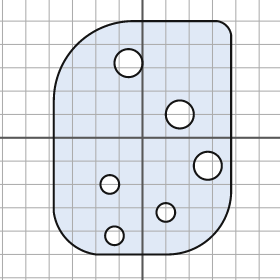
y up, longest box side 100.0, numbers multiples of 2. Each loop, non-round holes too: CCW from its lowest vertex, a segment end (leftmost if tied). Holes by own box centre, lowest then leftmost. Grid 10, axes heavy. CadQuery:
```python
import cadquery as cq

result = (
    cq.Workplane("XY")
    .moveTo(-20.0, -50.0)
    .lineTo(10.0, -50.0)
    .threePointArc((30.0, -42.0), (38.0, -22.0))
    .lineTo(38.0, 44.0)
    .threePointArc((36.0, 48.0), (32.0, 50.0))
    .lineTo(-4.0, 50.0)
    .threePointArc((-28.0, 40.0), (-38.0, 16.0))
    .lineTo(-38.0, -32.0)
    .threePointArc((-32.0, -44.0), (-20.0, -50.0))
    .close()
    .moveTo(-12.0, -42.0)
    .circle(4.0)
    .moveTo(10.0, -32.0)
    .circle(4.0)
    .moveTo(-14.0, -20.0)
    .circle(4.0)
    .moveTo(28.0, -12.0)
    .circle(6.0)
    .moveTo(16.0, 10.0)
    .circle(6.0)
    .moveTo(-6.0, 32.0)
    .circle(6.0)
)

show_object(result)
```